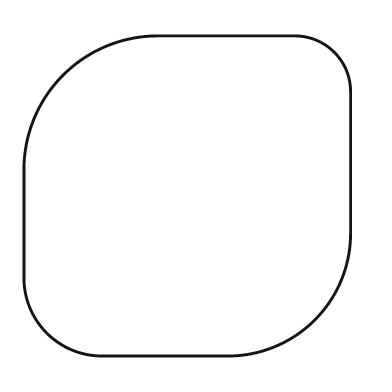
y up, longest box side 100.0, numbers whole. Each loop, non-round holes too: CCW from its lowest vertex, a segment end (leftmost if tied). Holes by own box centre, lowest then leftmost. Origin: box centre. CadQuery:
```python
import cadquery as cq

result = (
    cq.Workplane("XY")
    .moveTo(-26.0, -49.0)
    .lineTo(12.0, -49.0)
    .threePointArc((39.0, -38.0), (50.0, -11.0))
    .lineTo(50.0, 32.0)
    .threePointArc((45.0, 44.0), (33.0, 49.0))
    .lineTo(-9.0, 49.0)
    .threePointArc((-38.0, 37.0), (-50.0, 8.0))
    .lineTo(-50.0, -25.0)
    .threePointArc((-43.0, -42.0), (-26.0, -49.0))
    .close()
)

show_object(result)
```